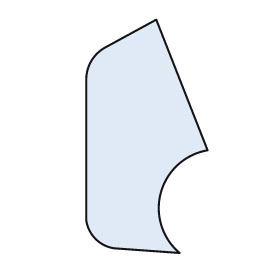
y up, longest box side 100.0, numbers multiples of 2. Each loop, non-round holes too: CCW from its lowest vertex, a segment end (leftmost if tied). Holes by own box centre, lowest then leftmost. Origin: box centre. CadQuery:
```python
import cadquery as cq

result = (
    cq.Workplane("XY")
    .moveTo(14.0, -50.0)
    .threePointArc((6.0, -24.0), (26.0, -6.0))
    .lineTo(4.0, 50.0)
    .lineTo(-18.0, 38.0)
    .threePointArc((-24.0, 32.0), (-26.0, 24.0))
    .lineTo(-26.0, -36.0)
    .threePointArc((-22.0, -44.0), (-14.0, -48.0))
    .close()
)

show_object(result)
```